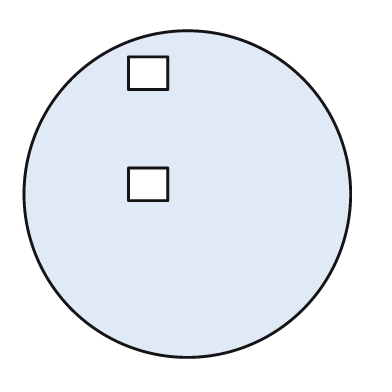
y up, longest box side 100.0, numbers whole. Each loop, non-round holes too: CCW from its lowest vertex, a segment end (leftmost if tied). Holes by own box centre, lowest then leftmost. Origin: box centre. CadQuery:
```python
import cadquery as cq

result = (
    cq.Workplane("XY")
    .moveTo(0.0, 0.0)
    .circle(50.0)
    .moveTo(-18.0, -2.0)
    .lineTo(-6.0, -2.0)
    .lineTo(-6.0, 8.0)
    .lineTo(-18.0, 8.0)
    .close()
    .moveTo(-18.0, 32.0)
    .lineTo(-6.0, 32.0)
    .lineTo(-6.0, 42.0)
    .lineTo(-18.0, 42.0)
    .close()
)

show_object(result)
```